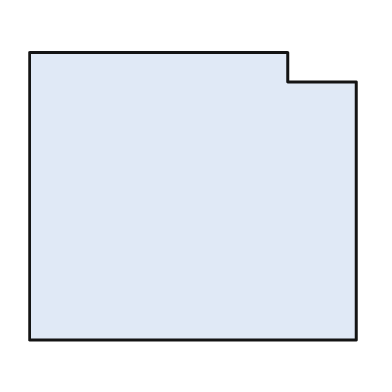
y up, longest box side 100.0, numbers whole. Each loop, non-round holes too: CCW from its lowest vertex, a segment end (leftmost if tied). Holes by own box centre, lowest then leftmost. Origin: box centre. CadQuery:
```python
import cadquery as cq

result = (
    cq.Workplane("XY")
    .moveTo(-50.0, -44.0)
    .lineTo(50.0, -44.0)
    .lineTo(50.0, 35.0)
    .lineTo(29.0, 35.0)
    .lineTo(29.0, 44.0)
    .lineTo(-50.0, 44.0)
    .close()
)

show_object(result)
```